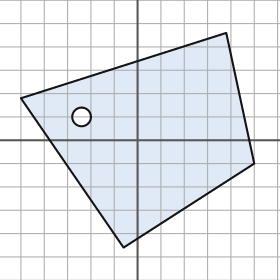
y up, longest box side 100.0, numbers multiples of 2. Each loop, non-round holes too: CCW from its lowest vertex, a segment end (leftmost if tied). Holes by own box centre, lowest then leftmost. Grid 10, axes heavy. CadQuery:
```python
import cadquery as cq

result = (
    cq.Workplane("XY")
    .moveTo(-6.0, -46.0)
    .lineTo(50.0, -10.0)
    .lineTo(38.0, 46.0)
    .lineTo(-50.0, 18.0)
    .close()
    .moveTo(-24.0, 10.0)
    .circle(4.0)
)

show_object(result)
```